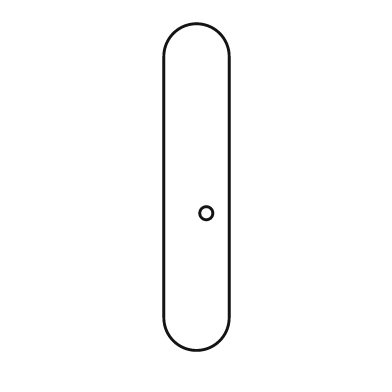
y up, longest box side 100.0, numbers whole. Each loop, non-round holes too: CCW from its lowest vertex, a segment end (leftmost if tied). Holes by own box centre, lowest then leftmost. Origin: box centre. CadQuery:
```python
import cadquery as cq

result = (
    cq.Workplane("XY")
    .moveTo(-10.0, -40.0)
    .threePointArc((0.0, -50.0), (10.0, -40.0))
    .lineTo(10.0, 40.0)
    .threePointArc((0.0, 50.0), (-10.0, 40.0))
    .close()
    .moveTo(3.0, -8.0)
    .circle(2.0)
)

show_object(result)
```